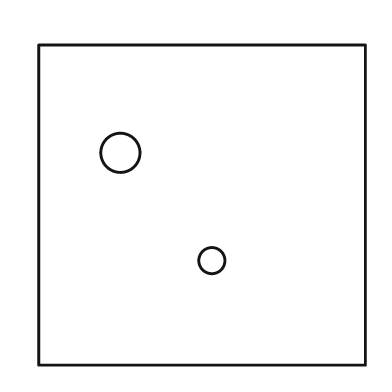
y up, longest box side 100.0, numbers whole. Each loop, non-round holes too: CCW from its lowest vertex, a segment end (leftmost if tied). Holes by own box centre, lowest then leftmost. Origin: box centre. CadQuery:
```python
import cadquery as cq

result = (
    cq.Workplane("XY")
    .moveTo(-50.0, -49.0)
    .lineTo(50.0, -49.0)
    .lineTo(50.0, 49.0)
    .lineTo(-50.0, 49.0)
    .close()
    .moveTo(3.0, -17.0)
    .circle(4.0)
    .moveTo(-25.0, 16.0)
    .circle(6.0)
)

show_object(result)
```